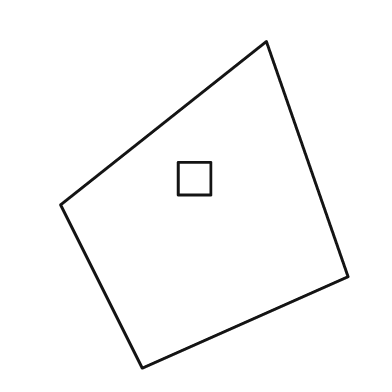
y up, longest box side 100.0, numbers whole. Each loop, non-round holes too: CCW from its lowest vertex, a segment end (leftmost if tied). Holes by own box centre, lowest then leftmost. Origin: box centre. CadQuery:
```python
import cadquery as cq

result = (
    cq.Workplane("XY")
    .moveTo(-19.0, -50.0)
    .lineTo(44.0, -22.0)
    .lineTo(19.0, 50.0)
    .lineTo(-44.0, 0.0)
    .close()
    .moveTo(-8.0, 3.0)
    .lineTo(2.0, 3.0)
    .lineTo(2.0, 13.0)
    .lineTo(-8.0, 13.0)
    .close()
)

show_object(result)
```